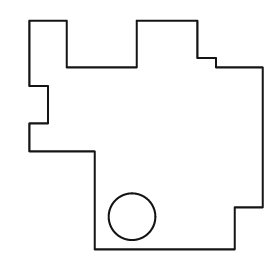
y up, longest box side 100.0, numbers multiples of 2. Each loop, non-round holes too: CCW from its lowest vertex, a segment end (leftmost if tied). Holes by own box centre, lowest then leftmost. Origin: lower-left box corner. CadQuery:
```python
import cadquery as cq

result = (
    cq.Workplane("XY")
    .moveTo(28.0, 0.0)
    .lineTo(88.0, 0.0)
    .lineTo(88.0, 18.0)
    .lineTo(100.0, 18.0)
    .lineTo(100.0, 78.0)
    .lineTo(80.0, 78.0)
    .lineTo(80.0, 82.0)
    .lineTo(72.0, 82.0)
    .lineTo(72.0, 98.0)
    .lineTo(46.0, 98.0)
    .lineTo(46.0, 78.0)
    .lineTo(16.0, 78.0)
    .lineTo(16.0, 98.0)
    .lineTo(0.0, 98.0)
    .lineTo(0.0, 70.0)
    .lineTo(8.0, 70.0)
    .lineTo(8.0, 54.0)
    .lineTo(0.0, 54.0)
    .lineTo(0.0, 42.0)
    .lineTo(28.0, 42.0)
    .close()
    .moveTo(44.0, 14.0)
    .circle(10.0)
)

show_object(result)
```